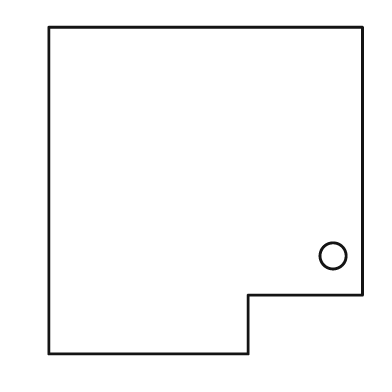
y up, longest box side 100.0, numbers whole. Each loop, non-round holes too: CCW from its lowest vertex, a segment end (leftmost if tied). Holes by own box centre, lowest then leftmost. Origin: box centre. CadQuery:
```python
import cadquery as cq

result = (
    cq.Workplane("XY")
    .moveTo(-48.0, -50.0)
    .lineTo(13.0, -50.0)
    .lineTo(13.0, -32.0)
    .lineTo(48.0, -32.0)
    .lineTo(48.0, 50.0)
    .lineTo(-48.0, 50.0)
    .close()
    .moveTo(39.0, -20.0)
    .circle(4.0)
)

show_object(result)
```